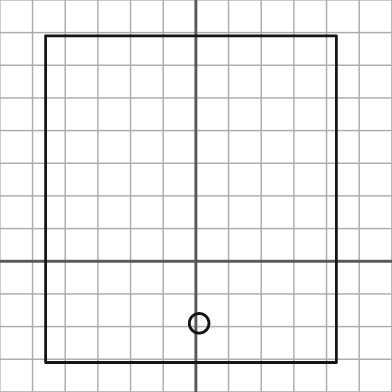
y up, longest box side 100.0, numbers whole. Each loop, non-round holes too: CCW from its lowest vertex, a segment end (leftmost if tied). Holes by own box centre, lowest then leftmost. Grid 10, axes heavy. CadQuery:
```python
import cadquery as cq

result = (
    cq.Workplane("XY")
    .moveTo(-46.0, -31.0)
    .lineTo(43.0, -31.0)
    .lineTo(43.0, 69.0)
    .lineTo(-46.0, 69.0)
    .close()
    .moveTo(1.0, -19.0)
    .circle(3.0)
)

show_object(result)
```